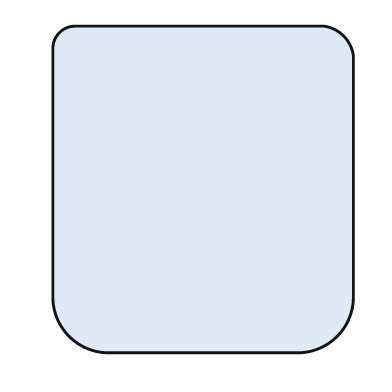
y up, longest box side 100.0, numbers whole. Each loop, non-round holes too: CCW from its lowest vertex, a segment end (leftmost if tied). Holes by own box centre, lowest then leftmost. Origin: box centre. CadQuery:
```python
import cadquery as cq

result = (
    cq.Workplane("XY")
    .moveTo(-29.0, -50.0)
    .lineTo(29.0, -50.0)
    .threePointArc((41.0, -45.0), (46.0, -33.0))
    .lineTo(46.0, 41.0)
    .threePointArc((43.0, 47.0), (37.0, 50.0))
    .lineTo(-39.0, 50.0)
    .threePointArc((-44.0, 48.0), (-46.0, 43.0))
    .lineTo(-46.0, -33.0)
    .threePointArc((-41.0, -45.0), (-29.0, -50.0))
    .close()
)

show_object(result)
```